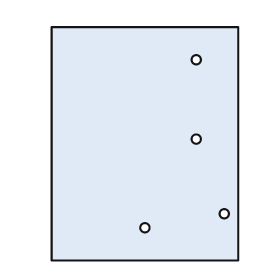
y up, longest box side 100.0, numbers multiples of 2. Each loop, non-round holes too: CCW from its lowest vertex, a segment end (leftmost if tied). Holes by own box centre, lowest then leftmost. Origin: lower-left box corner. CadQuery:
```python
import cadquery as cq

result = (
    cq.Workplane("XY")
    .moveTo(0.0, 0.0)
    .lineTo(80.0, 0.0)
    .lineTo(80.0, 100.0)
    .lineTo(0.0, 100.0)
    .close()
    .moveTo(40.0, 14.0)
    .circle(2.0)
    .moveTo(74.0, 20.0)
    .circle(2.0)
    .moveTo(62.0, 52.0)
    .circle(2.0)
    .moveTo(62.0, 86.0)
    .circle(2.0)
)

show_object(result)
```